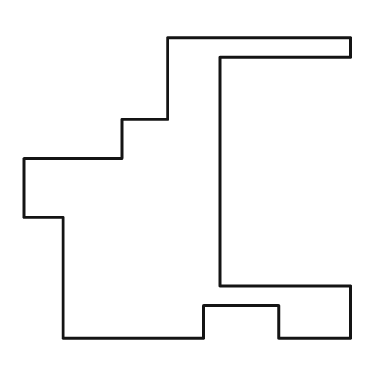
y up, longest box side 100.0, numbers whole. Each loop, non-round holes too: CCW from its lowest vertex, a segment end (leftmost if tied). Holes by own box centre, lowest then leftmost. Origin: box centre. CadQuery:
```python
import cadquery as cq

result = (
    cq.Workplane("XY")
    .moveTo(-38.0, -46.0)
    .lineTo(5.0, -46.0)
    .lineTo(5.0, -36.0)
    .lineTo(28.0, -36.0)
    .lineTo(28.0, -46.0)
    .lineTo(50.0, -46.0)
    .lineTo(50.0, -30.0)
    .lineTo(10.0, -30.0)
    .lineTo(10.0, 40.0)
    .lineTo(50.0, 40.0)
    .lineTo(50.0, 46.0)
    .lineTo(-6.0, 46.0)
    .lineTo(-6.0, 21.0)
    .lineTo(-20.0, 21.0)
    .lineTo(-20.0, 9.0)
    .lineTo(-50.0, 9.0)
    .lineTo(-50.0, -9.0)
    .lineTo(-38.0, -9.0)
    .close()
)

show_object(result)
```